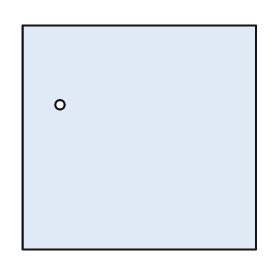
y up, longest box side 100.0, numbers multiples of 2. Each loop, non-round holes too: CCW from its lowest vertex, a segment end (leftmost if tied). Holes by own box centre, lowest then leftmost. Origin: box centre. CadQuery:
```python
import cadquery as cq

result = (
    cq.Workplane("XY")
    .moveTo(-50.0, -48.0)
    .lineTo(50.0, -48.0)
    .lineTo(50.0, 48.0)
    .lineTo(-50.0, 48.0)
    .close()
    .moveTo(-34.0, 14.0)
    .circle(2.0)
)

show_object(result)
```